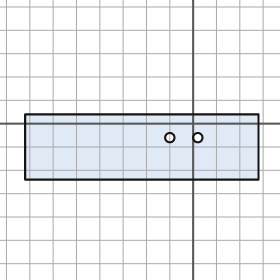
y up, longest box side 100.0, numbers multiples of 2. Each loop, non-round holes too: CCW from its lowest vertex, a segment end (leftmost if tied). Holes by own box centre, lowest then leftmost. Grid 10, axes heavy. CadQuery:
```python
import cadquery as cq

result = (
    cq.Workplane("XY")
    .moveTo(-72.0, -24.0)
    .lineTo(28.0, -24.0)
    .lineTo(28.0, 4.0)
    .lineTo(-72.0, 4.0)
    .close()
    .moveTo(-10.0, -6.0)
    .circle(2.0)
    .moveTo(2.0, -6.0)
    .circle(2.0)
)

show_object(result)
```